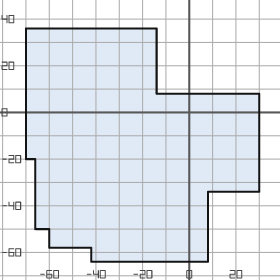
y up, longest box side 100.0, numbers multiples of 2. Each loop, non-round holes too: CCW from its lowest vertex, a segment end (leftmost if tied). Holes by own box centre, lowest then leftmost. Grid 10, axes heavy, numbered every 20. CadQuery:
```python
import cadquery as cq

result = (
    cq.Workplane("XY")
    .moveTo(-42.0, -64.0)
    .lineTo(8.0, -64.0)
    .lineTo(8.0, -34.0)
    .lineTo(30.0, -34.0)
    .lineTo(30.0, 8.0)
    .lineTo(-14.0, 8.0)
    .lineTo(-14.0, 36.0)
    .lineTo(-70.0, 36.0)
    .lineTo(-70.0, -20.0)
    .lineTo(-66.0, -20.0)
    .lineTo(-66.0, -50.0)
    .lineTo(-60.0, -50.0)
    .lineTo(-60.0, -58.0)
    .lineTo(-42.0, -58.0)
    .close()
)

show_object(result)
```